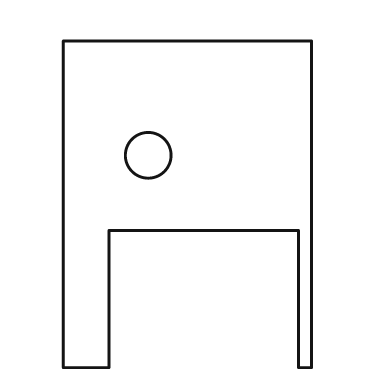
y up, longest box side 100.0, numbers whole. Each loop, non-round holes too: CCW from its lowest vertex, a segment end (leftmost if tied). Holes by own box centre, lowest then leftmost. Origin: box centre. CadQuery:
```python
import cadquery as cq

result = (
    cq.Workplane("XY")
    .moveTo(-38.0, -50.0)
    .lineTo(-24.0, -50.0)
    .lineTo(-24.0, -8.0)
    .lineTo(34.0, -8.0)
    .lineTo(34.0, -50.0)
    .lineTo(38.0, -50.0)
    .lineTo(38.0, 50.0)
    .lineTo(-38.0, 50.0)
    .close()
    .moveTo(-12.0, 15.0)
    .circle(7.0)
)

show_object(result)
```